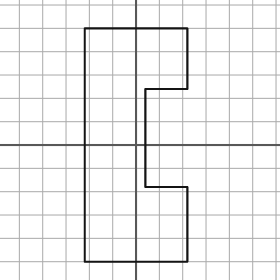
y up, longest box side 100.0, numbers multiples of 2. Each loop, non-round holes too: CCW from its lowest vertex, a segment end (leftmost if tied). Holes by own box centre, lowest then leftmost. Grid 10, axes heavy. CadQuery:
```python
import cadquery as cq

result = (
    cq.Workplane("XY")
    .moveTo(-22.0, -50.0)
    .lineTo(22.0, -50.0)
    .lineTo(22.0, -18.0)
    .lineTo(4.0, -18.0)
    .lineTo(4.0, 24.0)
    .lineTo(22.0, 24.0)
    .lineTo(22.0, 50.0)
    .lineTo(-22.0, 50.0)
    .close()
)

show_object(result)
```